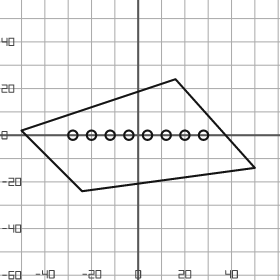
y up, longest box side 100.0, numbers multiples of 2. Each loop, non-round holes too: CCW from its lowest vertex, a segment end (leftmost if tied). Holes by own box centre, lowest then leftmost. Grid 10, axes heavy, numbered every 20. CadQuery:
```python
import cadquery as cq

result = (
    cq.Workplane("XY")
    .moveTo(-24.0, -24.0)
    .lineTo(50.0, -14.0)
    .lineTo(16.0, 24.0)
    .lineTo(-50.0, 2.0)
    .close()
    .moveTo(-28.0, 0.0)
    .circle(2.0)
    .moveTo(-20.0, 0.0)
    .circle(2.0)
    .moveTo(-12.0, 0.0)
    .circle(2.0)
    .moveTo(-4.0, 0.0)
    .circle(2.0)
    .moveTo(4.0, 0.0)
    .circle(2.0)
    .moveTo(12.0, 0.0)
    .circle(2.0)
    .moveTo(20.0, 0.0)
    .circle(2.0)
    .moveTo(28.0, 0.0)
    .circle(2.0)
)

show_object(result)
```